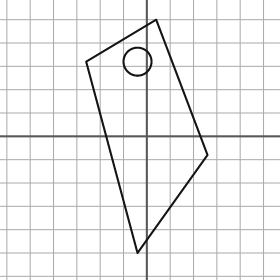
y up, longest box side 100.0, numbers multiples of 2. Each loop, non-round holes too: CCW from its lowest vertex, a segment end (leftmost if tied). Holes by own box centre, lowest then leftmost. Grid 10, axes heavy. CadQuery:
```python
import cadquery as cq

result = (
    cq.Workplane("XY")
    .moveTo(-4.0, -50.0)
    .lineTo(26.0, -8.0)
    .lineTo(4.0, 50.0)
    .lineTo(-26.0, 32.0)
    .close()
    .moveTo(-4.0, 32.0)
    .circle(6.0)
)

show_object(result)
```